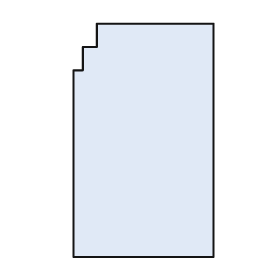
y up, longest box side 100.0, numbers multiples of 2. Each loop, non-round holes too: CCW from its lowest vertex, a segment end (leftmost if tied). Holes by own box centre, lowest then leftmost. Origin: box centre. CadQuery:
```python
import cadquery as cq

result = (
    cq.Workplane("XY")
    .moveTo(-30.0, -50.0)
    .lineTo(30.0, -50.0)
    .lineTo(30.0, 50.0)
    .lineTo(-20.0, 50.0)
    .lineTo(-20.0, 40.0)
    .lineTo(-26.0, 40.0)
    .lineTo(-26.0, 30.0)
    .lineTo(-30.0, 30.0)
    .close()
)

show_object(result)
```